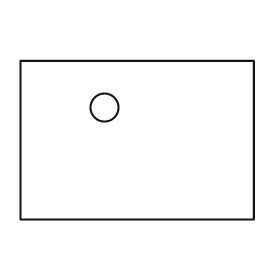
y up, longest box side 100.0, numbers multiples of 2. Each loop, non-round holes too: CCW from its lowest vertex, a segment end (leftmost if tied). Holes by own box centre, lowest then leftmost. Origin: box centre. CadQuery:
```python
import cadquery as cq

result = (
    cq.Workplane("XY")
    .moveTo(-50.0, -34.0)
    .lineTo(50.0, -34.0)
    .lineTo(50.0, 34.0)
    .lineTo(-50.0, 34.0)
    .close()
    .moveTo(-14.0, 14.0)
    .circle(6.0)
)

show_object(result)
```